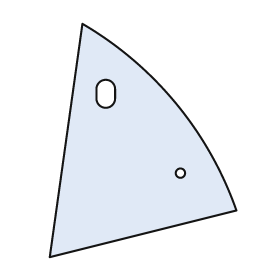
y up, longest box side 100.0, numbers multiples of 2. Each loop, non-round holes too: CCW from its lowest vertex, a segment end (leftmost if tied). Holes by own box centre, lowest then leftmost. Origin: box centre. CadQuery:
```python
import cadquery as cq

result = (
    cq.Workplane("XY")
    .moveTo(-40.0, -50.0)
    .lineTo(40.0, -30.0)
    .threePointArc((14.0, 16.0), (-26.0, 50.0))
    .close()
    .moveTo(16.0, -14.0)
    .circle(2.0)
    .moveTo(-20.0, 18.0)
    .threePointArc((-16.0, 14.0), (-12.0, 18.0))
    .lineTo(-12.0, 22.0)
    .threePointArc((-16.0, 26.0), (-20.0, 22.0))
    .close()
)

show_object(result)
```